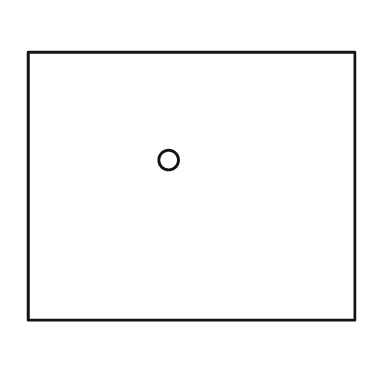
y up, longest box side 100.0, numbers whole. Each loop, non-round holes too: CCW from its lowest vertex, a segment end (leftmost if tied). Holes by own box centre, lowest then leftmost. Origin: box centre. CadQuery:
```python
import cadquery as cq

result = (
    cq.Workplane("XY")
    .moveTo(-50.0, -41.0)
    .lineTo(50.0, -41.0)
    .lineTo(50.0, 41.0)
    .lineTo(-50.0, 41.0)
    .close()
    .moveTo(-7.0, 8.0)
    .circle(3.0)
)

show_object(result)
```